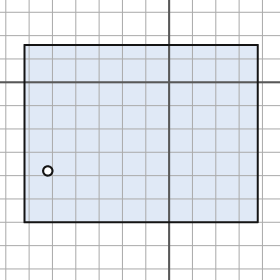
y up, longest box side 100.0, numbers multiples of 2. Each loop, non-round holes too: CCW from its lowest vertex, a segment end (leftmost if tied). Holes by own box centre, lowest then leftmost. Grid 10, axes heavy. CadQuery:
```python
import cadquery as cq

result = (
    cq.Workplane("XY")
    .moveTo(-62.0, -60.0)
    .lineTo(38.0, -60.0)
    .lineTo(38.0, 16.0)
    .lineTo(-62.0, 16.0)
    .close()
    .moveTo(-52.0, -38.0)
    .circle(2.0)
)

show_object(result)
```